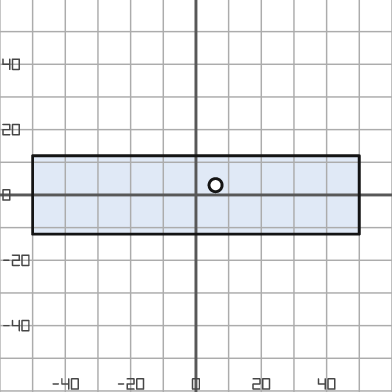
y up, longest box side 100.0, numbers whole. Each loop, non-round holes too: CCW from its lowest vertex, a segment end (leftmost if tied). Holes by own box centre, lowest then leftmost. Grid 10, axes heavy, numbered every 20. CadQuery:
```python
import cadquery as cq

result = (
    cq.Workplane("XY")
    .moveTo(-50.0, -12.0)
    .lineTo(50.0, -12.0)
    .lineTo(50.0, 12.0)
    .lineTo(-50.0, 12.0)
    .close()
    .moveTo(6.0, 3.0)
    .circle(2.0)
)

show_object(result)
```